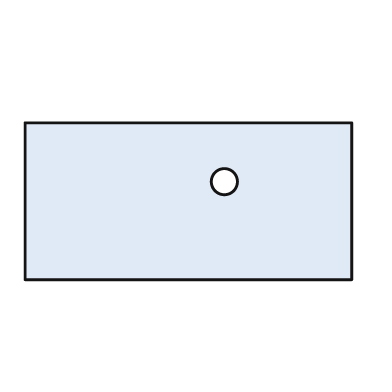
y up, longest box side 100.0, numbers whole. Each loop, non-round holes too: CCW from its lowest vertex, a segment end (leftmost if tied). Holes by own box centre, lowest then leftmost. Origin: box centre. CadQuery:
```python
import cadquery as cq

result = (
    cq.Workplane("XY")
    .moveTo(-50.0, -24.0)
    .lineTo(50.0, -24.0)
    .lineTo(50.0, 24.0)
    .lineTo(-50.0, 24.0)
    .close()
    .moveTo(11.0, 6.0)
    .circle(4.0)
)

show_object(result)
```